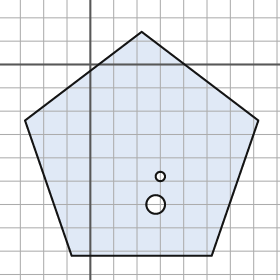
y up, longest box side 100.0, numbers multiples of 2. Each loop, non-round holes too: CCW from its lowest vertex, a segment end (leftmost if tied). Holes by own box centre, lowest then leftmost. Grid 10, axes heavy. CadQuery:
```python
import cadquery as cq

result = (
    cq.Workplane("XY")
    .moveTo(-8.0, -82.0)
    .lineTo(52.0, -82.0)
    .lineTo(72.0, -24.0)
    .lineTo(22.0, 14.0)
    .lineTo(-28.0, -24.0)
    .close()
    .moveTo(28.0, -60.0)
    .circle(4.0)
    .moveTo(30.0, -48.0)
    .circle(2.0)
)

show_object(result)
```